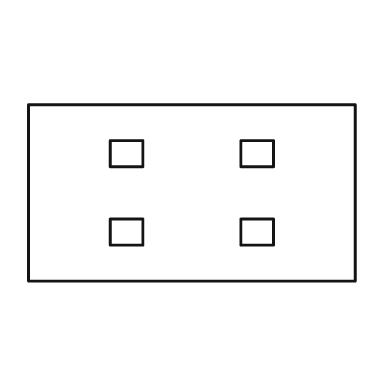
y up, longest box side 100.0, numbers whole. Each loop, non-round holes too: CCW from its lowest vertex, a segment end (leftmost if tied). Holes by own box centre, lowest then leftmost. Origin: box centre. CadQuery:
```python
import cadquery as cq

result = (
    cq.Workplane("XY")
    .moveTo(-50.0, -27.0)
    .lineTo(50.0, -27.0)
    .lineTo(50.0, 27.0)
    .lineTo(-50.0, 27.0)
    .close()
    .moveTo(-25.0, -16.0)
    .lineTo(-15.0, -16.0)
    .lineTo(-15.0, -8.0)
    .lineTo(-25.0, -8.0)
    .close()
    .moveTo(15.0, -16.0)
    .lineTo(25.0, -16.0)
    .lineTo(25.0, -8.0)
    .lineTo(15.0, -8.0)
    .close()
    .moveTo(-25.0, 8.0)
    .lineTo(-15.0, 8.0)
    .lineTo(-15.0, 16.0)
    .lineTo(-25.0, 16.0)
    .close()
    .moveTo(15.0, 8.0)
    .lineTo(25.0, 8.0)
    .lineTo(25.0, 16.0)
    .lineTo(15.0, 16.0)
    .close()
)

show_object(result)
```